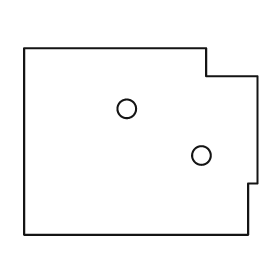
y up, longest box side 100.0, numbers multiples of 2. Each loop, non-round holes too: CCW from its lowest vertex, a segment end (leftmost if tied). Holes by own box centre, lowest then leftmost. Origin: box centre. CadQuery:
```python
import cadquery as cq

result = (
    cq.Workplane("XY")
    .moveTo(-50.0, -40.0)
    .lineTo(46.0, -40.0)
    .lineTo(46.0, -18.0)
    .lineTo(50.0, -18.0)
    .lineTo(50.0, 28.0)
    .lineTo(28.0, 28.0)
    .lineTo(28.0, 40.0)
    .lineTo(-50.0, 40.0)
    .close()
    .moveTo(26.0, -6.0)
    .circle(4.0)
    .moveTo(-6.0, 14.0)
    .circle(4.0)
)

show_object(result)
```